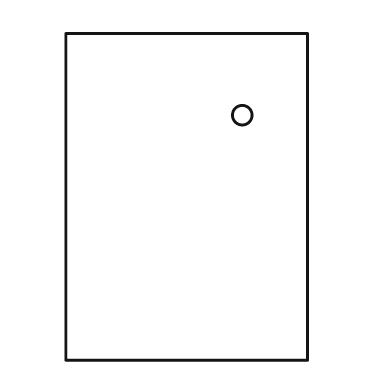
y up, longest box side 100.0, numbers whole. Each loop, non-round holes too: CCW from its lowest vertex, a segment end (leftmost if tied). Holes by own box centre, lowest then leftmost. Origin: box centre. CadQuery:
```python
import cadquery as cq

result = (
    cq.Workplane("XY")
    .moveTo(-37.0, -50.0)
    .lineTo(37.0, -50.0)
    .lineTo(37.0, 50.0)
    .lineTo(-37.0, 50.0)
    .close()
    .moveTo(17.0, 25.0)
    .circle(3.0)
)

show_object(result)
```